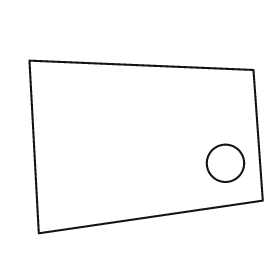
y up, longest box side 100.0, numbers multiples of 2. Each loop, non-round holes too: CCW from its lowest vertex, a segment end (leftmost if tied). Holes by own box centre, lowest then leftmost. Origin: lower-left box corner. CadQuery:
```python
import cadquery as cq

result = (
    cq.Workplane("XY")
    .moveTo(4.0, 0.0)
    .lineTo(100.0, 14.0)
    .lineTo(96.0, 70.0)
    .lineTo(0.0, 74.0)
    .close()
    .moveTo(84.0, 30.0)
    .circle(8.0)
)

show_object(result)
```